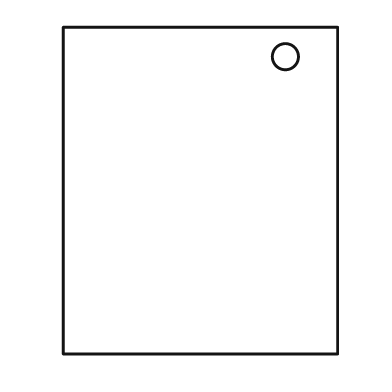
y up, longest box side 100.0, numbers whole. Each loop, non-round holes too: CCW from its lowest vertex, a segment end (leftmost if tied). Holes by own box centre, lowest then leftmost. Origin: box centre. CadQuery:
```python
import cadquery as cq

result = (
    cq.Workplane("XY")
    .moveTo(-42.0, -50.0)
    .lineTo(42.0, -50.0)
    .lineTo(42.0, 50.0)
    .lineTo(-42.0, 50.0)
    .close()
    .moveTo(26.0, 41.0)
    .circle(4.0)
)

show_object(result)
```